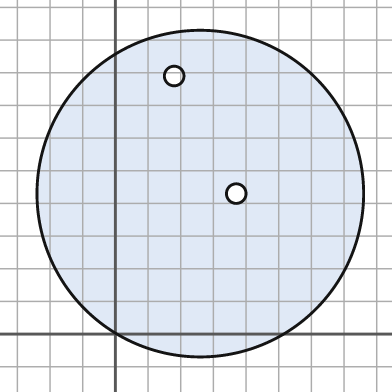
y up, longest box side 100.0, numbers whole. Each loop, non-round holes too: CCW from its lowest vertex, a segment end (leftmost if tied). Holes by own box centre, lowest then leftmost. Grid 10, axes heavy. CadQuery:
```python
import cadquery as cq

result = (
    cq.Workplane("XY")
    .moveTo(26.0, 43.0)
    .circle(50.0)
    .moveTo(37.0, 43.0)
    .circle(3.0)
    .moveTo(18.0, 79.0)
    .circle(3.0)
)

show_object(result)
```